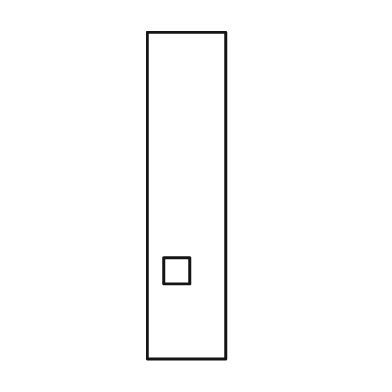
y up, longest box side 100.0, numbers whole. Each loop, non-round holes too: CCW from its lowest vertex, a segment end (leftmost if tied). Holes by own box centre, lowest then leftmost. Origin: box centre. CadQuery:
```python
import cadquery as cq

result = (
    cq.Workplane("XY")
    .moveTo(-12.0, -50.0)
    .lineTo(12.0, -50.0)
    .lineTo(12.0, 50.0)
    .lineTo(-12.0, 50.0)
    .close()
    .moveTo(-7.0, -27.0)
    .lineTo(1.0, -27.0)
    .lineTo(1.0, -19.0)
    .lineTo(-7.0, -19.0)
    .close()
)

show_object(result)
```